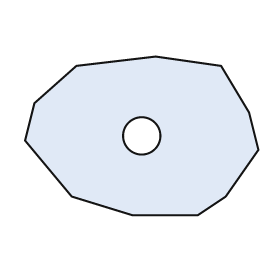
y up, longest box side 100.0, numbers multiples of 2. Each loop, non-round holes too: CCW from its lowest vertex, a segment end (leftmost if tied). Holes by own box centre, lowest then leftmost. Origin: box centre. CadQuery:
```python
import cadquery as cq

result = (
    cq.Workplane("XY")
    .moveTo(-4.0, -34.0)
    .lineTo(24.0, -34.0)
    .lineTo(36.0, -26.0)
    .lineTo(50.0, -6.0)
    .lineTo(46.0, 10.0)
    .lineTo(34.0, 30.0)
    .lineTo(6.0, 34.0)
    .lineTo(-28.0, 30.0)
    .lineTo(-46.0, 14.0)
    .lineTo(-50.0, -2.0)
    .lineTo(-30.0, -26.0)
    .close()
    .moveTo(0.0, 0.0)
    .circle(8.0)
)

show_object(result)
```